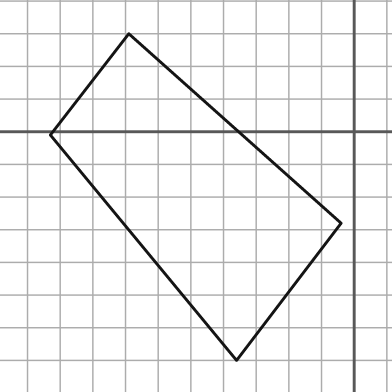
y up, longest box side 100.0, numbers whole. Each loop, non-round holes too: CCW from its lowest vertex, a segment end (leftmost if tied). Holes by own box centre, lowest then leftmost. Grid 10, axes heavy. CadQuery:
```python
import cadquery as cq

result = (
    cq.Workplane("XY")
    .moveTo(-36.0, -70.0)
    .lineTo(-4.0, -28.0)
    .lineTo(-69.0, 30.0)
    .lineTo(-93.0, -1.0)
    .close()
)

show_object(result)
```